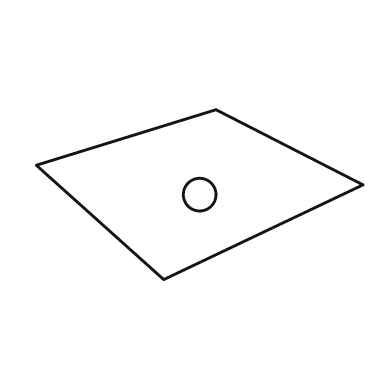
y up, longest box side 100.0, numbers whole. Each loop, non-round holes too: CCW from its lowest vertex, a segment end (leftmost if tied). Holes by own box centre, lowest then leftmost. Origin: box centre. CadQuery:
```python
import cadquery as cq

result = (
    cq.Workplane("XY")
    .moveTo(-11.0, -26.0)
    .lineTo(50.0, 3.0)
    .lineTo(5.0, 26.0)
    .lineTo(-50.0, 9.0)
    .close()
    .moveTo(0.0, 0.0)
    .circle(5.0)
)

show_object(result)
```